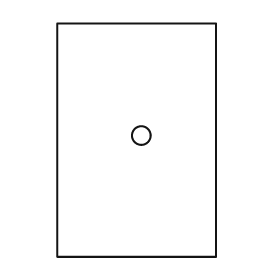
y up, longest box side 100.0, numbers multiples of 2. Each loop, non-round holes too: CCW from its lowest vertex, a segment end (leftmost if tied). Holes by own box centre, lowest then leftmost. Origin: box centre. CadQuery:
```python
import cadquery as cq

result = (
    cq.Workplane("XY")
    .moveTo(-34.0, -50.0)
    .lineTo(34.0, -50.0)
    .lineTo(34.0, 50.0)
    .lineTo(-34.0, 50.0)
    .close()
    .moveTo(2.0, 2.0)
    .circle(4.0)
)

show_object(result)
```